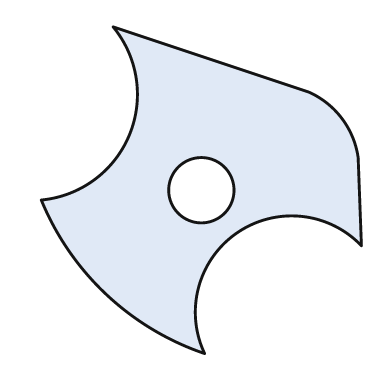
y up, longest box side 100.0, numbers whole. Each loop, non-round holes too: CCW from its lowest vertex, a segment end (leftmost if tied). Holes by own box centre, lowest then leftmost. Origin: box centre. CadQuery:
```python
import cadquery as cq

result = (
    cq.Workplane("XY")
    .moveTo(1.0, -50.0)
    .threePointArc((11.0, -13.0), (49.0, -17.0))
    .lineTo(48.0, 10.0)
    .threePointArc((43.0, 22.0), (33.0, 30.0))
    .lineTo(-27.0, 50.0)
    .threePointArc((-22.0, 17.0), (-49.0, -3.0))
    .threePointArc((-29.0, -32.0), (1.0, -50.0))
    .close()
    .moveTo(0.0, 0.0)
    .circle(10.0)
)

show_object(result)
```